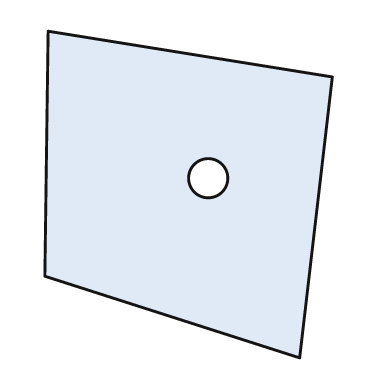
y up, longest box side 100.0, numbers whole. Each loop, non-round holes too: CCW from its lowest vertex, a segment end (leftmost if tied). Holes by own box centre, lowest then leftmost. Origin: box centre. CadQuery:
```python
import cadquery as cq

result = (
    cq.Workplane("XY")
    .moveTo(34.0, -50.0)
    .lineTo(44.0, 36.0)
    .lineTo(-43.0, 50.0)
    .lineTo(-44.0, -25.0)
    .close()
    .moveTo(6.0, 5.0)
    .circle(6.0)
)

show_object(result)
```